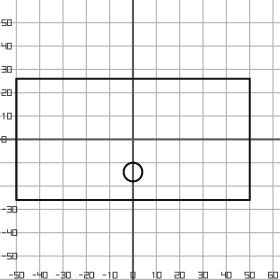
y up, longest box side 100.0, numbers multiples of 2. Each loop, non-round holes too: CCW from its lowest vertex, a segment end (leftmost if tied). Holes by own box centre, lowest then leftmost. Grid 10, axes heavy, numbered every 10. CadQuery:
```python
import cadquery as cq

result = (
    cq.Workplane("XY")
    .moveTo(-50.0, -26.0)
    .lineTo(50.0, -26.0)
    .lineTo(50.0, 26.0)
    .lineTo(-50.0, 26.0)
    .close()
    .moveTo(0.0, -14.0)
    .circle(4.0)
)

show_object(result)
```